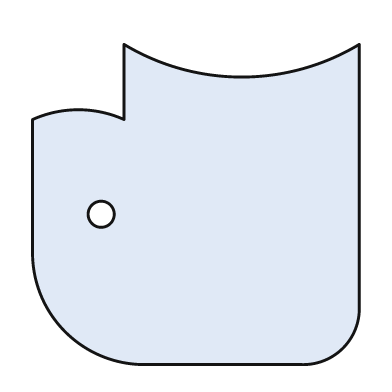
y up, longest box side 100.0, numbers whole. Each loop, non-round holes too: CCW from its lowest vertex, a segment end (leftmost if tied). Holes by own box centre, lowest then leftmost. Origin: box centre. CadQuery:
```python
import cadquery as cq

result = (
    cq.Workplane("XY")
    .moveTo(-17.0, -49.0)
    .lineTo(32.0, -49.0)
    .threePointArc((45.0, -44.0), (50.0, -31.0))
    .lineTo(50.0, 49.0)
    .threePointArc((14.0, 39.0), (-22.0, 49.0))
    .lineTo(-22.0, 26.0)
    .threePointArc((-36.0, 29.0), (-50.0, 26.0))
    .lineTo(-50.0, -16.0)
    .threePointArc((-40.0, -39.0), (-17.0, -49.0))
    .close()
    .moveTo(-29.0, -3.0)
    .circle(4.0)
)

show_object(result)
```